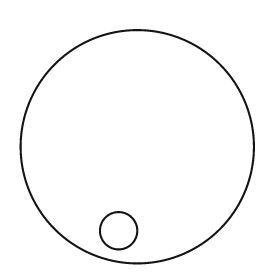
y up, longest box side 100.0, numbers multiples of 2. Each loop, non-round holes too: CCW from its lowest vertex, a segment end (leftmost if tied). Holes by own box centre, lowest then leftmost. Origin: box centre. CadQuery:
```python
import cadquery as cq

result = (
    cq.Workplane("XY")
    .moveTo(0.0, 0.0)
    .circle(50.0)
    .moveTo(-8.0, -36.0)
    .circle(8.0)
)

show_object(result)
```